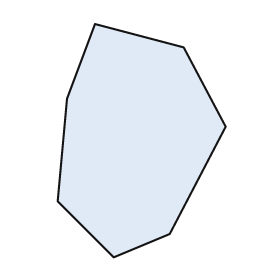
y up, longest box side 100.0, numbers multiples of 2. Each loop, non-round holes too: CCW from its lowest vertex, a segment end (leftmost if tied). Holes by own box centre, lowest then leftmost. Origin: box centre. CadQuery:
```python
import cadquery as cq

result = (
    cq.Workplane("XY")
    .moveTo(-12.0, -50.0)
    .lineTo(12.0, -40.0)
    .lineTo(36.0, 6.0)
    .lineTo(18.0, 40.0)
    .lineTo(-20.0, 50.0)
    .lineTo(-32.0, 18.0)
    .lineTo(-36.0, -26.0)
    .close()
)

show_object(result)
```